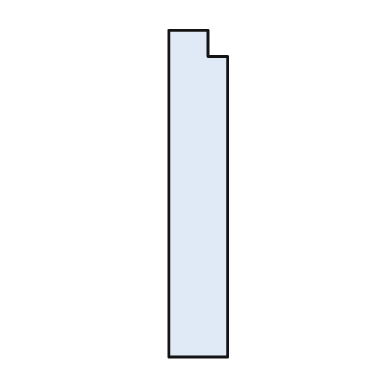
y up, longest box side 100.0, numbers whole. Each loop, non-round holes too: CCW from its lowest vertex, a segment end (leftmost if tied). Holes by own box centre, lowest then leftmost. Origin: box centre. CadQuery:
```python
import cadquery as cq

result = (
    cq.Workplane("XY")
    .moveTo(-9.0, -50.0)
    .lineTo(9.0, -50.0)
    .lineTo(9.0, 42.0)
    .lineTo(3.0, 42.0)
    .lineTo(3.0, 50.0)
    .lineTo(-9.0, 50.0)
    .close()
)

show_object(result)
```